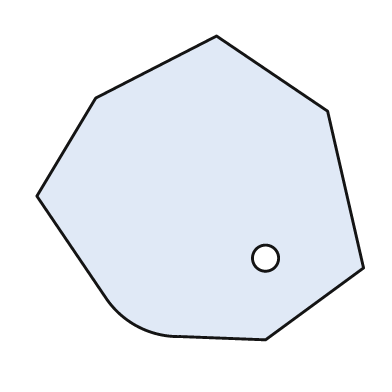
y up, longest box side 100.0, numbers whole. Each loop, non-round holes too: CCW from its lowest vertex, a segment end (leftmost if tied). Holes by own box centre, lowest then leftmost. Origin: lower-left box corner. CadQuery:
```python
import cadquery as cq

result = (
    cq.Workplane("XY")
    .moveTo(70.0, 0.0)
    .lineTo(100.0, 22.0)
    .lineTo(89.0, 70.0)
    .lineTo(55.0, 93.0)
    .lineTo(18.0, 74.0)
    .lineTo(0.0, 44.0)
    .lineTo(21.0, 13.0)
    .threePointArc((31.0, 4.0), (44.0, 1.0))
    .close()
    .moveTo(70.0, 25.0)
    .circle(4.0)
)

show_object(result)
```